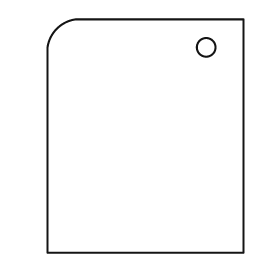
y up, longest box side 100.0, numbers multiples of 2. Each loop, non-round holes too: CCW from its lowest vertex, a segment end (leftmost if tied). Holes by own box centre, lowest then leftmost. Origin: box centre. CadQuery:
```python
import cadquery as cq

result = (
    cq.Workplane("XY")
    .moveTo(-42.0, -50.0)
    .lineTo(42.0, -50.0)
    .lineTo(42.0, 50.0)
    .lineTo(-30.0, 50.0)
    .threePointArc((-38.0, 46.0), (-42.0, 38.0))
    .close()
    .moveTo(26.0, 38.0)
    .circle(4.0)
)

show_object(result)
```